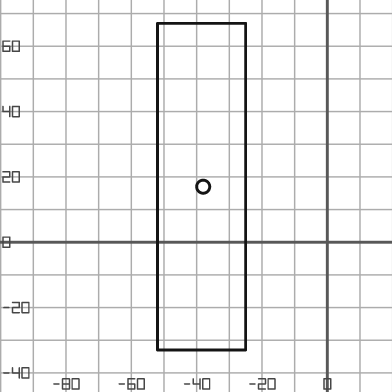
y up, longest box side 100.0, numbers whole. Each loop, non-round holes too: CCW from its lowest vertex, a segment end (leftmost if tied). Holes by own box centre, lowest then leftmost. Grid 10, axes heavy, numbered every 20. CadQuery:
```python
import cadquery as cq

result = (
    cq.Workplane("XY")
    .moveTo(-52.0, -33.0)
    .lineTo(-25.0, -33.0)
    .lineTo(-25.0, 67.0)
    .lineTo(-52.0, 67.0)
    .close()
    .moveTo(-38.0, 17.0)
    .circle(2.0)
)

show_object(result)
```